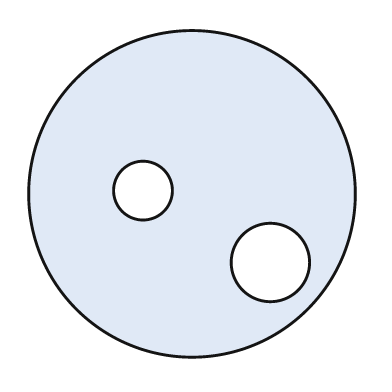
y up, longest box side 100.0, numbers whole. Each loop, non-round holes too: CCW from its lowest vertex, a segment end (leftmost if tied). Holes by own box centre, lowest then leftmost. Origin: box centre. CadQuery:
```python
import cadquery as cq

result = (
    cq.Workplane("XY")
    .moveTo(0.0, 0.0)
    .circle(50.0)
    .moveTo(24.0, -21.0)
    .circle(12.0)
    .moveTo(-15.0, 1.0)
    .circle(9.0)
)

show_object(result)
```